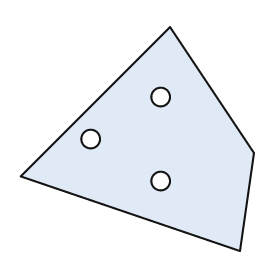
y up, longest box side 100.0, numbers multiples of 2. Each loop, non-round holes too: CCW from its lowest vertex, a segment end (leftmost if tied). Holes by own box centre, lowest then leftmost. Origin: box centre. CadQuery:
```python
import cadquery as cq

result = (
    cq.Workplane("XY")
    .moveTo(44.0, -48.0)
    .lineTo(50.0, -6.0)
    .lineTo(14.0, 48.0)
    .lineTo(-50.0, -16.0)
    .close()
    .moveTo(10.0, -18.0)
    .circle(4.0)
    .moveTo(-20.0, 0.0)
    .circle(4.0)
    .moveTo(10.0, 18.0)
    .circle(4.0)
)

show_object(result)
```